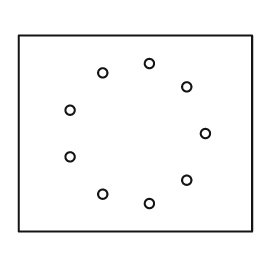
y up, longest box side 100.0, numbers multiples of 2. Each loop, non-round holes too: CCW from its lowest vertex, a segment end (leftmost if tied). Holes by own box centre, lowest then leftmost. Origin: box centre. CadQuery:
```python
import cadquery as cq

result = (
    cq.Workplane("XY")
    .moveTo(-50.0, -42.0)
    .lineTo(50.0, -42.0)
    .lineTo(50.0, 42.0)
    .lineTo(-50.0, 42.0)
    .close()
    .moveTo(6.0, -30.0)
    .circle(2.0)
    .moveTo(-14.0, -26.0)
    .circle(2.0)
    .moveTo(22.0, -20.0)
    .circle(2.0)
    .moveTo(-28.0, -10.0)
    .circle(2.0)
    .moveTo(30.0, 0.0)
    .circle(2.0)
    .moveTo(-28.0, 10.0)
    .circle(2.0)
    .moveTo(22.0, 20.0)
    .circle(2.0)
    .moveTo(-14.0, 26.0)
    .circle(2.0)
    .moveTo(6.0, 30.0)
    .circle(2.0)
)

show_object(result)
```